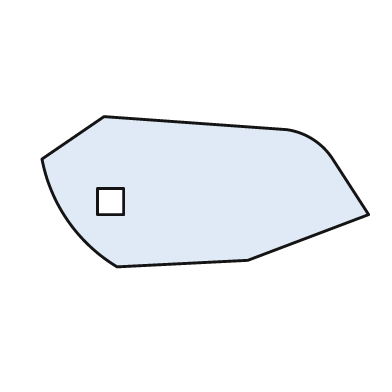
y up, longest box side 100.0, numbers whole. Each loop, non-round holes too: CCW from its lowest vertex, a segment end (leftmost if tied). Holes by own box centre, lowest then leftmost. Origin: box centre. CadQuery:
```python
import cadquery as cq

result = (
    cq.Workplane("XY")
    .moveTo(-27.0, -23.0)
    .lineTo(13.0, -21.0)
    .lineTo(50.0, -7.0)
    .lineTo(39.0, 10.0)
    .threePointArc((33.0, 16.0), (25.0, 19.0))
    .lineTo(-31.0, 23.0)
    .lineTo(-50.0, 10.0)
    .threePointArc((-42.0, -9.0), (-27.0, -23.0))
    .close()
    .moveTo(-33.0, -7.0)
    .lineTo(-25.0, -7.0)
    .lineTo(-25.0, 1.0)
    .lineTo(-33.0, 1.0)
    .close()
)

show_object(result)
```